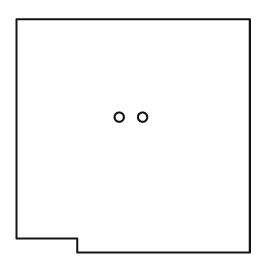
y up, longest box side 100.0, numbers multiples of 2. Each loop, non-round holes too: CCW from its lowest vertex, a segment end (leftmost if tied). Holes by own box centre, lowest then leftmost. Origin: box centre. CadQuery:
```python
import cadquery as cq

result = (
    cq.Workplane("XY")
    .moveTo(-24.0, -50.0)
    .lineTo(50.0, -50.0)
    .lineTo(50.0, 50.0)
    .lineTo(-50.0, 50.0)
    .lineTo(-50.0, -44.0)
    .lineTo(-24.0, -44.0)
    .close()
    .moveTo(-6.0, 8.0)
    .circle(2.0)
    .moveTo(4.0, 8.0)
    .circle(2.0)
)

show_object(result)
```